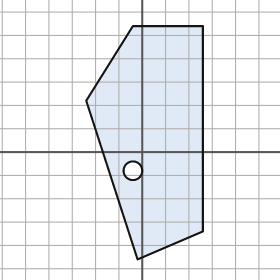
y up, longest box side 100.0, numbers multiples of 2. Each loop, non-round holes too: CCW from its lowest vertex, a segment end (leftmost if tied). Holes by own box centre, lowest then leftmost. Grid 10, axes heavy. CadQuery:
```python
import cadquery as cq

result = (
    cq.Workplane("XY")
    .moveTo(-2.0, -46.0)
    .lineTo(26.0, -34.0)
    .lineTo(26.0, 54.0)
    .lineTo(-4.0, 54.0)
    .lineTo(-24.0, 22.0)
    .close()
    .moveTo(-4.0, -8.0)
    .circle(4.0)
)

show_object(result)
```